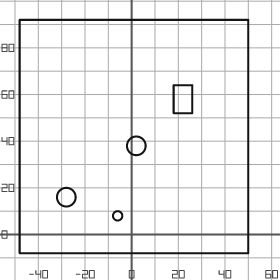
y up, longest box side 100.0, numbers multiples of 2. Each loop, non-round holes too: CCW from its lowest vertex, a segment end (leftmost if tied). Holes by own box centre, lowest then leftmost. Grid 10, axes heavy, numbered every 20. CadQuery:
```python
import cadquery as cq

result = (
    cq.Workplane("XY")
    .moveTo(-48.0, -8.0)
    .lineTo(50.0, -8.0)
    .lineTo(50.0, 92.0)
    .lineTo(-48.0, 92.0)
    .close()
    .moveTo(-6.0, 8.0)
    .circle(2.0)
    .moveTo(-28.0, 16.0)
    .circle(4.0)
    .moveTo(2.0, 38.0)
    .circle(4.0)
    .moveTo(18.0, 52.0)
    .lineTo(26.0, 52.0)
    .lineTo(26.0, 64.0)
    .lineTo(18.0, 64.0)
    .close()
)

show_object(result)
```